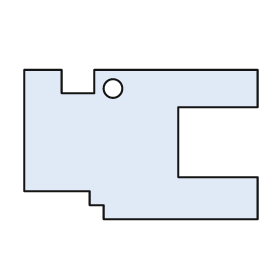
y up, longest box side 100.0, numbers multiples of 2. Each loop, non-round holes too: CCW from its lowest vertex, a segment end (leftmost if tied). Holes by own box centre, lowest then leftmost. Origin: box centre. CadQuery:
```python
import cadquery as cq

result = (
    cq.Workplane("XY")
    .moveTo(-16.0, -32.0)
    .lineTo(50.0, -32.0)
    .lineTo(50.0, -14.0)
    .lineTo(16.0, -14.0)
    .lineTo(16.0, 16.0)
    .lineTo(50.0, 16.0)
    .lineTo(50.0, 32.0)
    .lineTo(-20.0, 32.0)
    .lineTo(-20.0, 22.0)
    .lineTo(-34.0, 22.0)
    .lineTo(-34.0, 32.0)
    .lineTo(-50.0, 32.0)
    .lineTo(-50.0, -20.0)
    .lineTo(-22.0, -20.0)
    .lineTo(-22.0, -26.0)
    .lineTo(-16.0, -26.0)
    .close()
    .moveTo(-12.0, 24.0)
    .circle(4.0)
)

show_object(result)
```